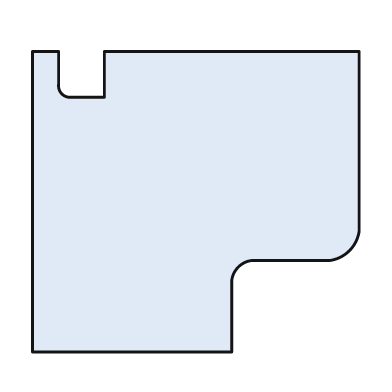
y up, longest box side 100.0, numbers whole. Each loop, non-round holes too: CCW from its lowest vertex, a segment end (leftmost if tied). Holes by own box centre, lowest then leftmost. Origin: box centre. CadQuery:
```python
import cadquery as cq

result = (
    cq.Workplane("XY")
    .moveTo(-50.0, -46.0)
    .lineTo(11.0, -46.0)
    .lineTo(11.0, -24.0)
    .threePointArc((13.0, -20.0), (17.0, -18.0))
    .lineTo(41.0, -18.0)
    .threePointArc((47.0, -15.0), (50.0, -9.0))
    .lineTo(50.0, 46.0)
    .lineTo(-28.0, 46.0)
    .lineTo(-28.0, 32.0)
    .lineTo(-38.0, 32.0)
    .threePointArc((-41.0, 33.0), (-42.0, 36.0))
    .lineTo(-42.0, 46.0)
    .lineTo(-50.0, 46.0)
    .close()
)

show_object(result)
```